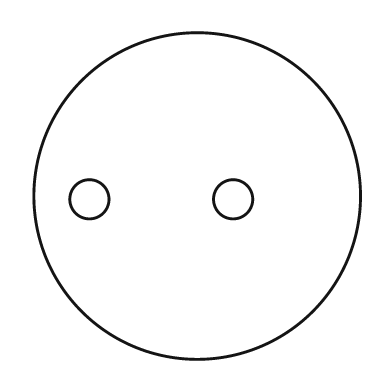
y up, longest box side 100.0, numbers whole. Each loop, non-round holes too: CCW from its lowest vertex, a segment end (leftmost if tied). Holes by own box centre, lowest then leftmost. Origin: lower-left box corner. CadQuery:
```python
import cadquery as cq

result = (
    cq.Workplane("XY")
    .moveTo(50.0, 50.0)
    .circle(50.0)
    .moveTo(17.0, 49.0)
    .circle(6.0)
    .moveTo(61.0, 49.0)
    .circle(6.0)
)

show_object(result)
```